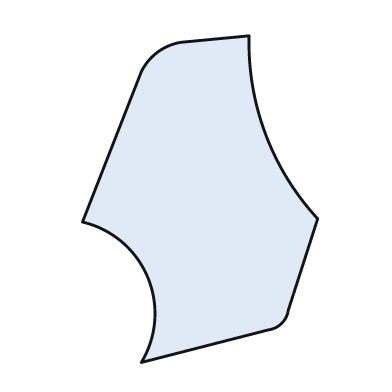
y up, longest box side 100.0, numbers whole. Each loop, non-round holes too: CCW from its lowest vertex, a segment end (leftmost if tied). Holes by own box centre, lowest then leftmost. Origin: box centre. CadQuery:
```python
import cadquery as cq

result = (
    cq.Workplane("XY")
    .moveTo(-18.0, -50.0)
    .lineTo(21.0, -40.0)
    .threePointArc((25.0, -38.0), (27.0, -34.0))
    .lineTo(36.0, -6.0)
    .threePointArc((20.0, 20.0), (15.0, 50.0))
    .lineTo(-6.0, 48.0)
    .threePointArc((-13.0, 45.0), (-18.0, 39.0))
    .lineTo(-36.0, -7.0)
    .threePointArc((-16.0, -24.0), (-18.0, -50.0))
    .close()
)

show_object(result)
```